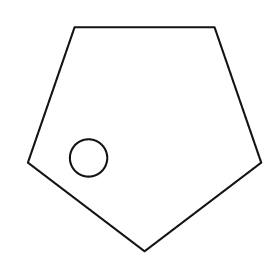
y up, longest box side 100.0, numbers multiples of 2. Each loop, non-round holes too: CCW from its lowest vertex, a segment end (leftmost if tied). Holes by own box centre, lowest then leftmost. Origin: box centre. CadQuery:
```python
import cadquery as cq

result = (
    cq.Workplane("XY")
    .moveTo(0.0, -48.0)
    .lineTo(50.0, -10.0)
    .lineTo(30.0, 48.0)
    .lineTo(-30.0, 48.0)
    .lineTo(-50.0, -10.0)
    .close()
    .moveTo(-24.0, -8.0)
    .circle(8.0)
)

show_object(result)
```